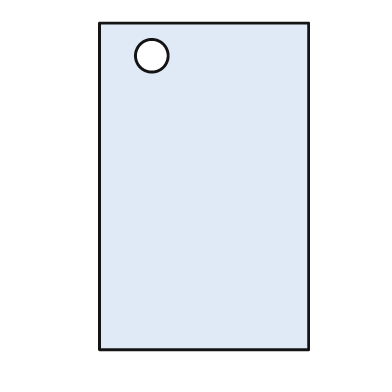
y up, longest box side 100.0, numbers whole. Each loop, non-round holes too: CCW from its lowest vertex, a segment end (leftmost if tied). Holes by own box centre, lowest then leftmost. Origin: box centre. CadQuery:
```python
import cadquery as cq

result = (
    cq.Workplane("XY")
    .moveTo(-32.0, -50.0)
    .lineTo(32.0, -50.0)
    .lineTo(32.0, 50.0)
    .lineTo(-32.0, 50.0)
    .close()
    .moveTo(-16.0, 40.0)
    .circle(5.0)
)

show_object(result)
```